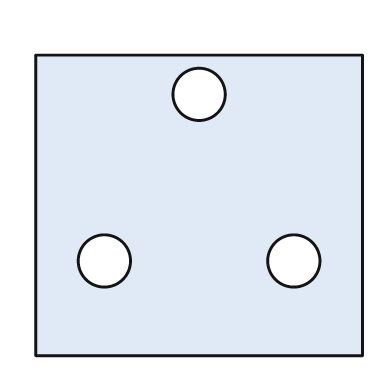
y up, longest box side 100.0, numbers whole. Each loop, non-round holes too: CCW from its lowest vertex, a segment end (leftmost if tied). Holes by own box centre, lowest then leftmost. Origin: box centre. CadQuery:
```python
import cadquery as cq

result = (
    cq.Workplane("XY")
    .moveTo(-50.0, -46.0)
    .lineTo(50.0, -46.0)
    .lineTo(50.0, 46.0)
    .lineTo(-50.0, 46.0)
    .close()
    .moveTo(-29.0, -17.0)
    .circle(8.0)
    .moveTo(29.0, -17.0)
    .circle(8.0)
    .moveTo(0.0, 34.0)
    .circle(8.0)
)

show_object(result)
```